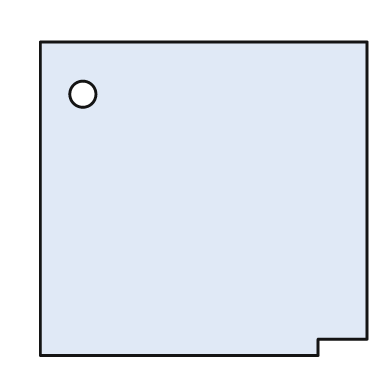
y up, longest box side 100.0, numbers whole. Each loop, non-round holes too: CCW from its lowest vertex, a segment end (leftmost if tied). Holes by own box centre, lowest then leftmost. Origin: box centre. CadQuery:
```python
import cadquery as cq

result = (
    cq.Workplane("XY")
    .moveTo(-50.0, -48.0)
    .lineTo(35.0, -48.0)
    .lineTo(35.0, -43.0)
    .lineTo(50.0, -43.0)
    .lineTo(50.0, 48.0)
    .lineTo(-50.0, 48.0)
    .close()
    .moveTo(-37.0, 32.0)
    .circle(4.0)
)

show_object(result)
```